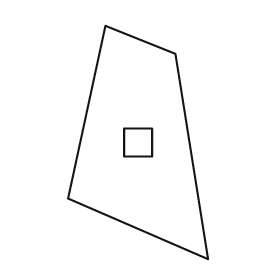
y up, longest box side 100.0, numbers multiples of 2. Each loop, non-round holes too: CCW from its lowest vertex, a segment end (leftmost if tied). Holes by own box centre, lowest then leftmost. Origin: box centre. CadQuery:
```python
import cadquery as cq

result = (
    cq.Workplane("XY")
    .moveTo(30.0, -50.0)
    .lineTo(16.0, 38.0)
    .lineTo(-14.0, 50.0)
    .lineTo(-30.0, -24.0)
    .close()
    .moveTo(-6.0, -6.0)
    .lineTo(6.0, -6.0)
    .lineTo(6.0, 6.0)
    .lineTo(-6.0, 6.0)
    .close()
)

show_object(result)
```